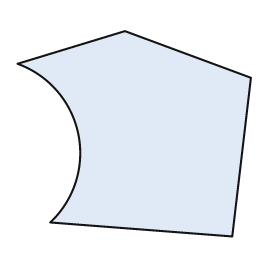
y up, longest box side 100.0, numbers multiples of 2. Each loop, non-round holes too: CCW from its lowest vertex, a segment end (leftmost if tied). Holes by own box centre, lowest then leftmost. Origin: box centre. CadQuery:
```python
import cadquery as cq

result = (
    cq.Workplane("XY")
    .moveTo(42.0, -44.0)
    .lineTo(50.0, 24.0)
    .lineTo(-4.0, 44.0)
    .lineTo(-50.0, 30.0)
    .threePointArc((-24.0, 0.0), (-36.0, -38.0))
    .close()
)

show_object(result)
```